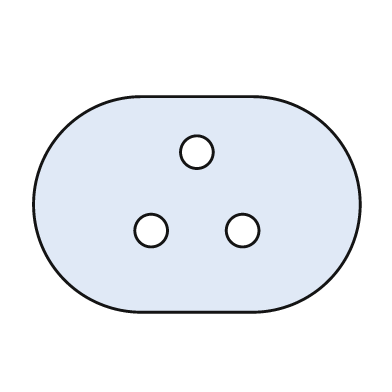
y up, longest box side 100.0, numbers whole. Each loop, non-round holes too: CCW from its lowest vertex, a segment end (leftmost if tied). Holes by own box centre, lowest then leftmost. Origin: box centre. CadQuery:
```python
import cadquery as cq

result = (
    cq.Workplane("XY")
    .moveTo(-17.0, -33.0)
    .lineTo(17.0, -33.0)
    .threePointArc((50.0, 0.0), (17.0, 33.0))
    .lineTo(-17.0, 33.0)
    .threePointArc((-50.0, 0.0), (-17.0, -33.0))
    .close()
    .moveTo(-14.0, -8.0)
    .circle(5.0)
    .moveTo(14.0, -8.0)
    .circle(5.0)
    .moveTo(0.0, 16.0)
    .circle(5.0)
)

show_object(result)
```